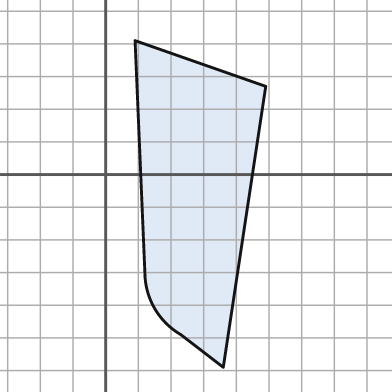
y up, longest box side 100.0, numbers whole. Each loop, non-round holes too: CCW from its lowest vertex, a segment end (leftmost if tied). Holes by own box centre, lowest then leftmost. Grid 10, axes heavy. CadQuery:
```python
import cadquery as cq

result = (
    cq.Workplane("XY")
    .moveTo(36.0, -59.0)
    .lineTo(49.0, 27.0)
    .lineTo(9.0, 41.0)
    .lineTo(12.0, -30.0)
    .threePointArc((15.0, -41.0), (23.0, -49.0))
    .close()
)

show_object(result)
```